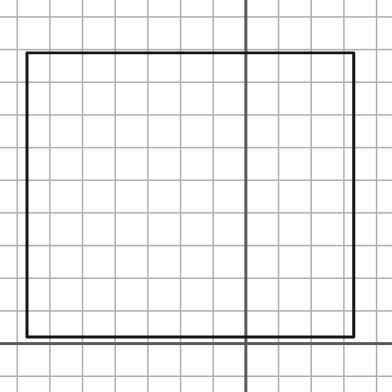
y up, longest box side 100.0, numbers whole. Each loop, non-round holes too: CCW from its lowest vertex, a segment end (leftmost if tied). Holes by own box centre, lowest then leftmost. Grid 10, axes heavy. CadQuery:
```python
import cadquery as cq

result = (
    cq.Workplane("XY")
    .moveTo(-67.0, 2.0)
    .lineTo(33.0, 2.0)
    .lineTo(33.0, 89.0)
    .lineTo(-67.0, 89.0)
    .close()
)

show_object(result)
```